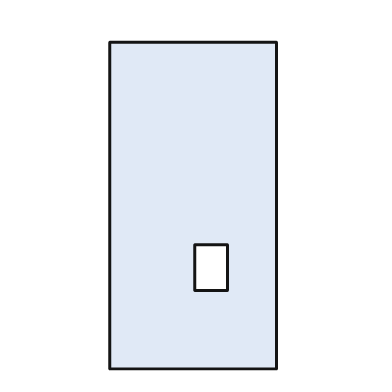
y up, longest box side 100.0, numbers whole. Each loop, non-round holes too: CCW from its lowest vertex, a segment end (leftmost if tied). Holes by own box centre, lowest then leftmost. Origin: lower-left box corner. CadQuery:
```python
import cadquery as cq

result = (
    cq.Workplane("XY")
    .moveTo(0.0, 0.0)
    .lineTo(51.0, 0.0)
    .lineTo(51.0, 100.0)
    .lineTo(0.0, 100.0)
    .close()
    .moveTo(26.0, 24.0)
    .lineTo(36.0, 24.0)
    .lineTo(36.0, 38.0)
    .lineTo(26.0, 38.0)
    .close()
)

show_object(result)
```